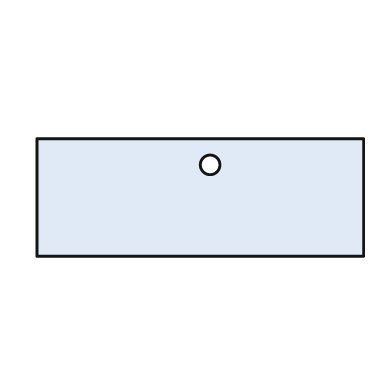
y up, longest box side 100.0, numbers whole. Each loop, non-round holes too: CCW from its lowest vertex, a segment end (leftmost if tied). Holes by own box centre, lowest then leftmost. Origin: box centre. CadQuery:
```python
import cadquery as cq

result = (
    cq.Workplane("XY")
    .moveTo(-50.0, -18.0)
    .lineTo(50.0, -18.0)
    .lineTo(50.0, 18.0)
    .lineTo(-50.0, 18.0)
    .close()
    .moveTo(3.0, 10.0)
    .circle(3.0)
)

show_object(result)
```